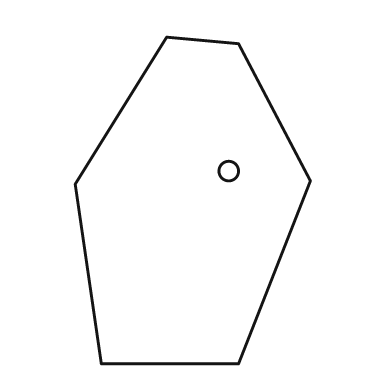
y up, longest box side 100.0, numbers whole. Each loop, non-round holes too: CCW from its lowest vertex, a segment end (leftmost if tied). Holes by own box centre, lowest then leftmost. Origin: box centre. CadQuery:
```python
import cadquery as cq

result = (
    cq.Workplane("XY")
    .moveTo(-28.0, -50.0)
    .lineTo(14.0, -50.0)
    .lineTo(36.0, 6.0)
    .lineTo(14.0, 48.0)
    .lineTo(-8.0, 50.0)
    .lineTo(-36.0, 5.0)
    .close()
    .moveTo(11.0, 9.0)
    .circle(3.0)
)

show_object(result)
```